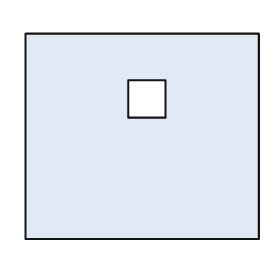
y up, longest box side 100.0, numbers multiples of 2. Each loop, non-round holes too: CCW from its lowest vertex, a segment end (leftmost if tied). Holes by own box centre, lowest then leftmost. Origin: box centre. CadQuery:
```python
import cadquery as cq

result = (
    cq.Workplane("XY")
    .moveTo(-50.0, -44.0)
    .lineTo(50.0, -44.0)
    .lineTo(50.0, 44.0)
    .lineTo(-50.0, 44.0)
    .close()
    .moveTo(-6.0, 8.0)
    .lineTo(10.0, 8.0)
    .lineTo(10.0, 24.0)
    .lineTo(-6.0, 24.0)
    .close()
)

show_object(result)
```